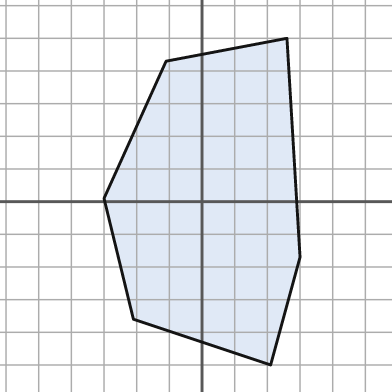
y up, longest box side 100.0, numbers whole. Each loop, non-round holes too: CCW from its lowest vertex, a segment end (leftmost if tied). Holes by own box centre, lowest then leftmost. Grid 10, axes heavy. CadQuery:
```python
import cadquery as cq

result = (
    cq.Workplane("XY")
    .moveTo(21.0, -50.0)
    .lineTo(30.0, -17.0)
    .lineTo(26.0, 50.0)
    .lineTo(-11.0, 43.0)
    .lineTo(-30.0, 1.0)
    .lineTo(-21.0, -36.0)
    .close()
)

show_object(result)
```